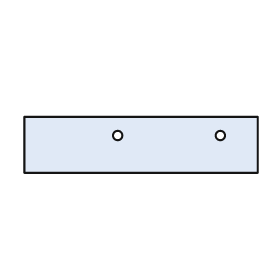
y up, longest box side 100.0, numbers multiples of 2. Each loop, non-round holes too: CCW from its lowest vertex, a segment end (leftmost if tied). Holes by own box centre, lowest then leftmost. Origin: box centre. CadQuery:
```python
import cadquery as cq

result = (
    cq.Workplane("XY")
    .moveTo(-50.0, -12.0)
    .lineTo(50.0, -12.0)
    .lineTo(50.0, 12.0)
    .lineTo(-50.0, 12.0)
    .close()
    .moveTo(-10.0, 4.0)
    .circle(2.0)
    .moveTo(34.0, 4.0)
    .circle(2.0)
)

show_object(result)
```